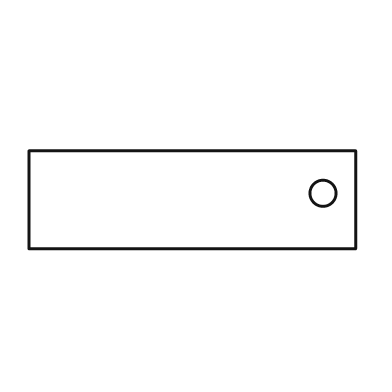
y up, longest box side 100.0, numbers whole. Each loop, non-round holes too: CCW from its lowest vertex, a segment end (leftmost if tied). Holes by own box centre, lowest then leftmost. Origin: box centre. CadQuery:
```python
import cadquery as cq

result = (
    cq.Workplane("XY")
    .moveTo(-50.0, -15.0)
    .lineTo(50.0, -15.0)
    .lineTo(50.0, 15.0)
    .lineTo(-50.0, 15.0)
    .close()
    .moveTo(40.0, 2.0)
    .circle(4.0)
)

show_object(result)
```